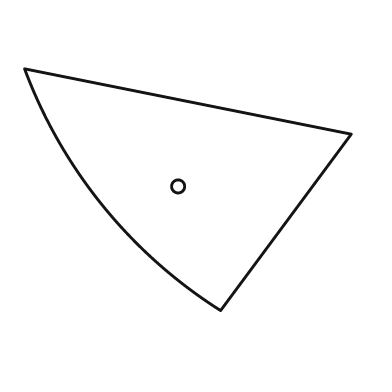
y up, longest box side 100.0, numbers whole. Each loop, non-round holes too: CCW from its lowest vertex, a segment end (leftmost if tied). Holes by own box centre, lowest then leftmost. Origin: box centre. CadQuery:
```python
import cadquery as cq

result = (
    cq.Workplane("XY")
    .moveTo(10.0, -37.0)
    .lineTo(50.0, 17.0)
    .lineTo(-50.0, 37.0)
    .threePointArc((-26.0, -5.0), (10.0, -37.0))
    .close()
    .moveTo(-3.0, 1.0)
    .circle(2.0)
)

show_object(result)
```